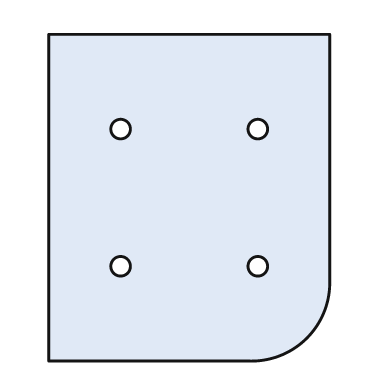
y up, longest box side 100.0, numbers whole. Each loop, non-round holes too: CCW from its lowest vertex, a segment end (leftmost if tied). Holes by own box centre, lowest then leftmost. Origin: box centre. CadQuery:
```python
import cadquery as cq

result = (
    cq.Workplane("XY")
    .moveTo(-43.0, -50.0)
    .lineTo(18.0, -50.0)
    .threePointArc((36.0, -43.0), (43.0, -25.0))
    .lineTo(43.0, 50.0)
    .lineTo(-43.0, 50.0)
    .close()
    .moveTo(-21.0, -21.0)
    .circle(3.0)
    .moveTo(21.0, -21.0)
    .circle(3.0)
    .moveTo(-21.0, 21.0)
    .circle(3.0)
    .moveTo(21.0, 21.0)
    .circle(3.0)
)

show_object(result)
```